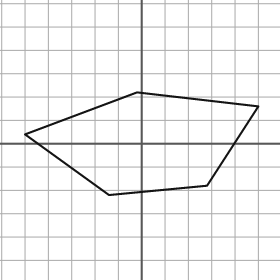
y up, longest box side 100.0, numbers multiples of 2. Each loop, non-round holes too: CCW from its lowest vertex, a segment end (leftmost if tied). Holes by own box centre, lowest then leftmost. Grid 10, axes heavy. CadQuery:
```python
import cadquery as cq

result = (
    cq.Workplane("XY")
    .moveTo(-14.0, -22.0)
    .lineTo(28.0, -18.0)
    .lineTo(50.0, 16.0)
    .lineTo(-2.0, 22.0)
    .lineTo(-50.0, 4.0)
    .close()
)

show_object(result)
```